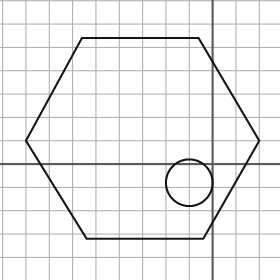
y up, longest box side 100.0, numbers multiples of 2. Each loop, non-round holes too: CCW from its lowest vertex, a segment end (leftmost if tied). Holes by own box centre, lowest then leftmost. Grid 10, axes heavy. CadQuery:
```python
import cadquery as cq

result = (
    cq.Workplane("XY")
    .moveTo(-54.0, -32.0)
    .lineTo(-4.0, -32.0)
    .lineTo(20.0, 10.0)
    .lineTo(-6.0, 54.0)
    .lineTo(-56.0, 54.0)
    .lineTo(-80.0, 10.0)
    .close()
    .moveTo(-10.0, -8.0)
    .circle(10.0)
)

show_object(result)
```